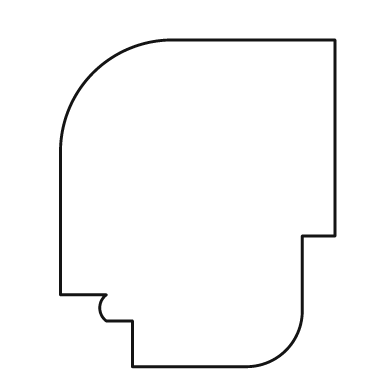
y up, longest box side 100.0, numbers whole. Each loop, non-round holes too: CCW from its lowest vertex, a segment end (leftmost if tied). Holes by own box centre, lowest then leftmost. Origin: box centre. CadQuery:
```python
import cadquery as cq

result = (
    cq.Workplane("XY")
    .moveTo(-20.0, -50.0)
    .lineTo(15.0, -50.0)
    .threePointArc((27.0, -45.0), (32.0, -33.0))
    .lineTo(32.0, -10.0)
    .lineTo(42.0, -10.0)
    .lineTo(42.0, 50.0)
    .lineTo(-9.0, 50.0)
    .threePointArc((-32.0, 40.0), (-42.0, 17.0))
    .lineTo(-42.0, -28.0)
    .lineTo(-28.0, -28.0)
    .threePointArc((-30.0, -32.0), (-28.0, -36.0))
    .lineTo(-20.0, -36.0)
    .close()
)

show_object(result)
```